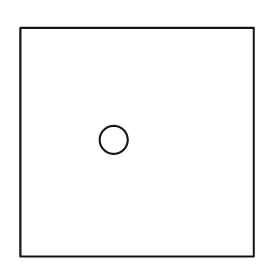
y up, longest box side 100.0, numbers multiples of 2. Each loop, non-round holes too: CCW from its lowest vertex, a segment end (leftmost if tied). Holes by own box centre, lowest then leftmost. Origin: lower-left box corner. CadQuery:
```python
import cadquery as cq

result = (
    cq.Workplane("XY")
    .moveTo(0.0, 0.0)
    .lineTo(100.0, 0.0)
    .lineTo(100.0, 98.0)
    .lineTo(0.0, 98.0)
    .close()
    .moveTo(40.0, 50.0)
    .circle(6.0)
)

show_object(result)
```